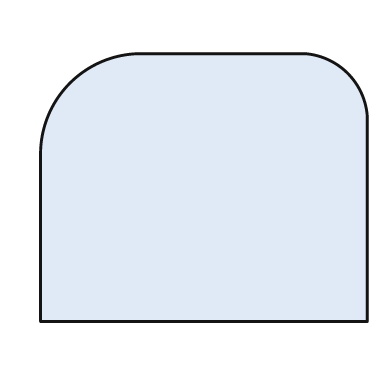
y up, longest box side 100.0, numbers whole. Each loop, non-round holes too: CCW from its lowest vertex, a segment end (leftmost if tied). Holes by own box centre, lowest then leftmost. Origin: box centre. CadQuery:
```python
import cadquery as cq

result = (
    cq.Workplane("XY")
    .moveTo(-50.0, -41.0)
    .lineTo(50.0, -41.0)
    .lineTo(50.0, 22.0)
    .threePointArc((44.0, 35.0), (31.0, 41.0))
    .lineTo(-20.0, 41.0)
    .threePointArc((-41.0, 32.0), (-50.0, 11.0))
    .close()
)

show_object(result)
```